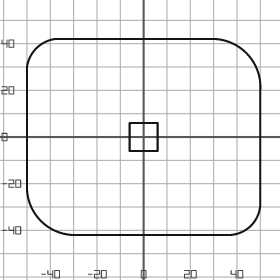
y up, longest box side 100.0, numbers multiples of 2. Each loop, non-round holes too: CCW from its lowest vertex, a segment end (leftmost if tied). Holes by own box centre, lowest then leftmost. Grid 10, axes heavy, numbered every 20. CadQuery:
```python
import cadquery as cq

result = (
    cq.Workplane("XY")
    .moveTo(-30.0, -42.0)
    .lineTo(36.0, -42.0)
    .threePointArc((46.0, -38.0), (50.0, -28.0))
    .lineTo(50.0, 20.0)
    .threePointArc((44.0, 36.0), (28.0, 42.0))
    .lineTo(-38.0, 42.0)
    .threePointArc((-46.0, 38.0), (-50.0, 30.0))
    .lineTo(-50.0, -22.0)
    .threePointArc((-44.0, -36.0), (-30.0, -42.0))
    .close()
    .moveTo(-6.0, -6.0)
    .lineTo(6.0, -6.0)
    .lineTo(6.0, 6.0)
    .lineTo(-6.0, 6.0)
    .close()
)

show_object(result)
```